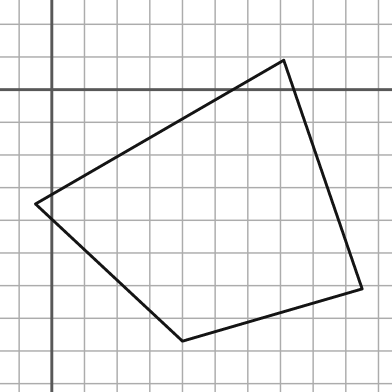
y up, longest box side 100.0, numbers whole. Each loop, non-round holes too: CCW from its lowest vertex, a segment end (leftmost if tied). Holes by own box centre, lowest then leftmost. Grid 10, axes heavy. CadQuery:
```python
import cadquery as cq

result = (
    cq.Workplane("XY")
    .moveTo(40.0, -77.0)
    .lineTo(95.0, -61.0)
    .lineTo(71.0, 9.0)
    .lineTo(-5.0, -35.0)
    .close()
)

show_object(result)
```